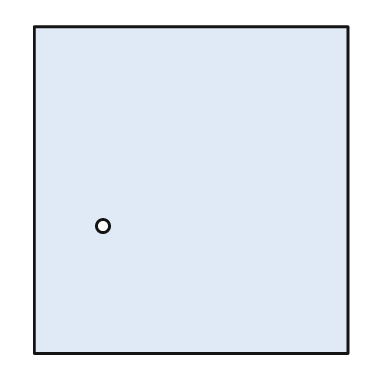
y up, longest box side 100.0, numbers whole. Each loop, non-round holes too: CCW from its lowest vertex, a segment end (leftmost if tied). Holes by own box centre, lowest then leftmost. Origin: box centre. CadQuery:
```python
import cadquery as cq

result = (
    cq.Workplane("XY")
    .moveTo(-48.0, -50.0)
    .lineTo(48.0, -50.0)
    .lineTo(48.0, 50.0)
    .lineTo(-48.0, 50.0)
    .close()
    .moveTo(-27.0, -11.0)
    .circle(2.0)
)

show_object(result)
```